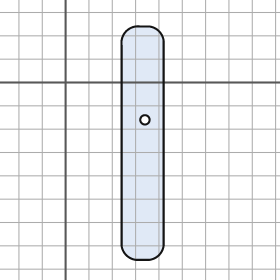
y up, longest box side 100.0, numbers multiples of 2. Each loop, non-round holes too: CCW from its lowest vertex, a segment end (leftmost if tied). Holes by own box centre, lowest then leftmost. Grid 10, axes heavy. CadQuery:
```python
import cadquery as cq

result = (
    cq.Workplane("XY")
    .moveTo(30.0, -76.0)
    .lineTo(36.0, -76.0)
    .threePointArc((40.0, -74.0), (42.0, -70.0))
    .lineTo(42.0, 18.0)
    .threePointArc((40.0, 22.0), (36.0, 24.0))
    .lineTo(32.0, 24.0)
    .threePointArc((26.0, 22.0), (24.0, 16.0))
    .lineTo(24.0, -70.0)
    .threePointArc((26.0, -74.0), (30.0, -76.0))
    .close()
    .moveTo(34.0, -16.0)
    .circle(2.0)
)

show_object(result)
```